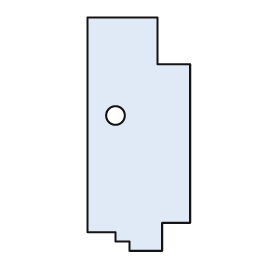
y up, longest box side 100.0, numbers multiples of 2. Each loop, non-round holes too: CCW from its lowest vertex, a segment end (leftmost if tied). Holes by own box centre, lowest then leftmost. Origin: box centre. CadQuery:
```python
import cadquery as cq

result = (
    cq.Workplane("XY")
    .moveTo(-4.0, -50.0)
    .lineTo(10.0, -50.0)
    .lineTo(10.0, -38.0)
    .lineTo(22.0, -38.0)
    .lineTo(22.0, 30.0)
    .lineTo(8.0, 30.0)
    .lineTo(8.0, 50.0)
    .lineTo(-22.0, 50.0)
    .lineTo(-22.0, -42.0)
    .lineTo(-10.0, -42.0)
    .lineTo(-10.0, -46.0)
    .lineTo(-4.0, -46.0)
    .close()
    .moveTo(-10.0, 8.0)
    .circle(4.0)
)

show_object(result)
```